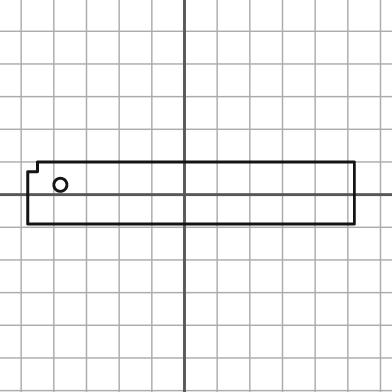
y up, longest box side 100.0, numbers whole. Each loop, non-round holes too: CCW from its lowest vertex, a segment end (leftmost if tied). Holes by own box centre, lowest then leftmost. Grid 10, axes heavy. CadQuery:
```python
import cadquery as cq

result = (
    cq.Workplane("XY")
    .moveTo(-48.0, -9.0)
    .lineTo(52.0, -9.0)
    .lineTo(52.0, 10.0)
    .lineTo(-45.0, 10.0)
    .lineTo(-45.0, 7.0)
    .lineTo(-48.0, 7.0)
    .close()
    .moveTo(-38.0, 3.0)
    .circle(2.0)
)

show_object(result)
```